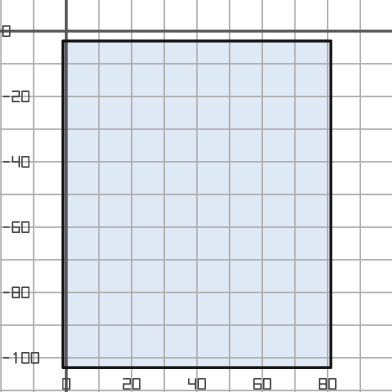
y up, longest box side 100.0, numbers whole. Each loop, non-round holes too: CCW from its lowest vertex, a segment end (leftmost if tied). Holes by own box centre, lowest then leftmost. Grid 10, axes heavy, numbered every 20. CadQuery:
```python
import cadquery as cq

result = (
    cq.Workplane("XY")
    .moveTo(-1.0, -103.0)
    .lineTo(81.0, -103.0)
    .lineTo(81.0, -3.0)
    .lineTo(-1.0, -3.0)
    .close()
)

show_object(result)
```